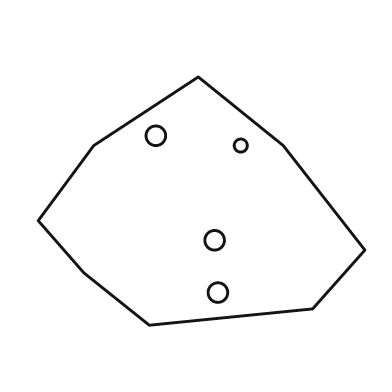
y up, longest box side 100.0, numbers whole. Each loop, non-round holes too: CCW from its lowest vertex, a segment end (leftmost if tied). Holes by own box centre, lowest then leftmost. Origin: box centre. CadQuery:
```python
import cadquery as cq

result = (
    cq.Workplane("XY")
    .moveTo(-16.0, -38.0)
    .lineTo(34.0, -33.0)
    .lineTo(50.0, -15.0)
    .lineTo(25.0, 17.0)
    .lineTo(-1.0, 38.0)
    .lineTo(-33.0, 17.0)
    .lineTo(-50.0, -6.0)
    .lineTo(-36.0, -22.0)
    .close()
    .moveTo(5.0, -28.0)
    .circle(3.0)
    .moveTo(4.0, -12.0)
    .circle(3.0)
    .moveTo(12.0, 17.0)
    .circle(2.0)
    .moveTo(-14.0, 20.0)
    .circle(3.0)
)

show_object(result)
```